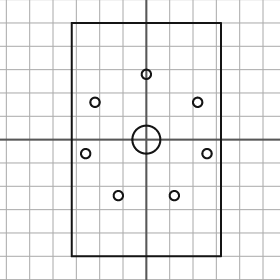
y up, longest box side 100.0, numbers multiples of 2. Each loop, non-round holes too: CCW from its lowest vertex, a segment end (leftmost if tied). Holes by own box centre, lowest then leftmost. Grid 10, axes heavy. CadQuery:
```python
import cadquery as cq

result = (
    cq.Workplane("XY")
    .moveTo(-32.0, -50.0)
    .lineTo(32.0, -50.0)
    .lineTo(32.0, 50.0)
    .lineTo(-32.0, 50.0)
    .close()
    .moveTo(-12.0, -24.0)
    .circle(2.0)
    .moveTo(12.0, -24.0)
    .circle(2.0)
    .moveTo(-26.0, -6.0)
    .circle(2.0)
    .moveTo(26.0, -6.0)
    .circle(2.0)
    .moveTo(0.0, 0.0)
    .circle(6.0)
    .moveTo(-22.0, 16.0)
    .circle(2.0)
    .moveTo(22.0, 16.0)
    .circle(2.0)
    .moveTo(0.0, 28.0)
    .circle(2.0)
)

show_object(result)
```